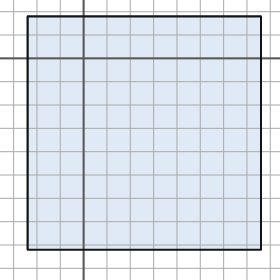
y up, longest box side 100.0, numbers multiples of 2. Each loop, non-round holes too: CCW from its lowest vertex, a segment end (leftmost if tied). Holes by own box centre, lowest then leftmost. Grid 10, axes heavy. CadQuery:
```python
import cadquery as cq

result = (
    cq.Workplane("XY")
    .moveTo(-24.0, -82.0)
    .lineTo(76.0, -82.0)
    .lineTo(76.0, 18.0)
    .lineTo(-24.0, 18.0)
    .close()
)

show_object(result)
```